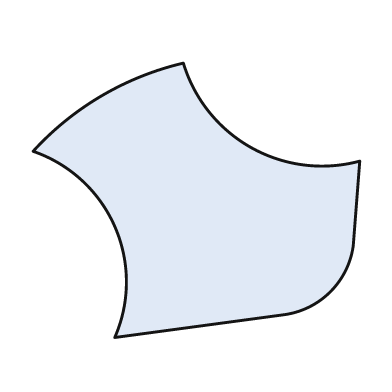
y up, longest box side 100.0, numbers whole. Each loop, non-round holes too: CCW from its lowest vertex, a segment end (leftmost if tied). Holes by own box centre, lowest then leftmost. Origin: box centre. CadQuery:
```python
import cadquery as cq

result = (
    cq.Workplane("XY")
    .moveTo(-25.0, -42.0)
    .lineTo(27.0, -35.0)
    .threePointArc((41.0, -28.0), (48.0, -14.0))
    .lineTo(50.0, 12.0)
    .threePointArc((17.0, 16.0), (-4.0, 42.0))
    .threePointArc((-29.0, 32.0), (-50.0, 15.0))
    .threePointArc((-25.0, -8.0), (-25.0, -42.0))
    .close()
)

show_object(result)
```